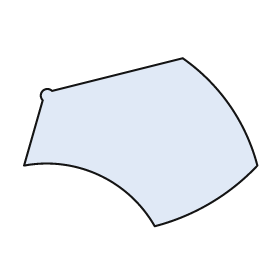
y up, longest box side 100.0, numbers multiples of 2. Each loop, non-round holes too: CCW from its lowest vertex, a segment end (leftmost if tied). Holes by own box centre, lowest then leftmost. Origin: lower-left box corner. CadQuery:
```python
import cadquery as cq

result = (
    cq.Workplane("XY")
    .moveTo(56.0, 0.0)
    .threePointArc((80.0, 10.0), (100.0, 26.0))
    .threePointArc((88.0, 52.0), (68.0, 72.0))
    .lineTo(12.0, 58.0)
    .threePointArc((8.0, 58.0), (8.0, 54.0))
    .lineTo(0.0, 26.0)
    .threePointArc((32.0, 22.0), (56.0, 0.0))
    .close()
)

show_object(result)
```